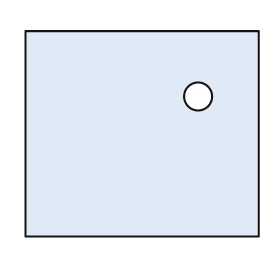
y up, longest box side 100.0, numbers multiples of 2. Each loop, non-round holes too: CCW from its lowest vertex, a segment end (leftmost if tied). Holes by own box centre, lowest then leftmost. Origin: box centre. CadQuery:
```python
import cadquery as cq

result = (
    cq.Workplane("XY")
    .moveTo(-50.0, -44.0)
    .lineTo(50.0, -44.0)
    .lineTo(50.0, 44.0)
    .lineTo(-50.0, 44.0)
    .close()
    .moveTo(24.0, 16.0)
    .circle(6.0)
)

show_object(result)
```